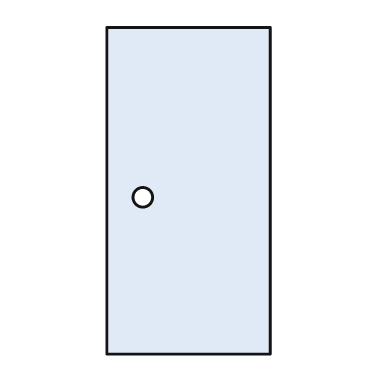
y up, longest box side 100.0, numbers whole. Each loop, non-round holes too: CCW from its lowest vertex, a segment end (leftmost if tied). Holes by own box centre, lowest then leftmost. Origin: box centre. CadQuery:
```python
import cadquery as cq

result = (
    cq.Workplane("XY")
    .moveTo(-25.0, -50.0)
    .lineTo(25.0, -50.0)
    .lineTo(25.0, 50.0)
    .lineTo(-25.0, 50.0)
    .close()
    .moveTo(-14.0, -2.0)
    .circle(3.0)
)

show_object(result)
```